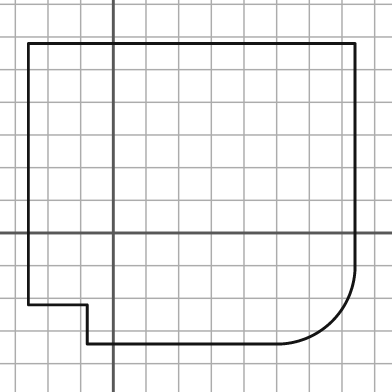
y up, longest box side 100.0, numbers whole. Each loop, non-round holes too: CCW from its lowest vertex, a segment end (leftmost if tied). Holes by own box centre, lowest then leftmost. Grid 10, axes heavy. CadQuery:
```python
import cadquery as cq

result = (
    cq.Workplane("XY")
    .moveTo(-8.0, -34.0)
    .lineTo(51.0, -34.0)
    .threePointArc((67.0, -27.0), (74.0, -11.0))
    .lineTo(74.0, 58.0)
    .lineTo(-26.0, 58.0)
    .lineTo(-26.0, -22.0)
    .lineTo(-8.0, -22.0)
    .close()
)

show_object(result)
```